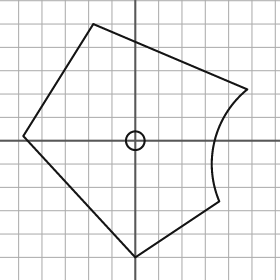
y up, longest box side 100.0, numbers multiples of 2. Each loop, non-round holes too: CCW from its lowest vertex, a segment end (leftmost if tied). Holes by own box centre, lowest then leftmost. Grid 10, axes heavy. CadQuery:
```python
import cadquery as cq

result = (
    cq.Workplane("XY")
    .moveTo(0.0, -50.0)
    .lineTo(36.0, -26.0)
    .threePointArc((34.0, 0.0), (48.0, 22.0))
    .lineTo(-18.0, 50.0)
    .lineTo(-48.0, 2.0)
    .close()
    .moveTo(0.0, 0.0)
    .circle(4.0)
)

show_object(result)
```